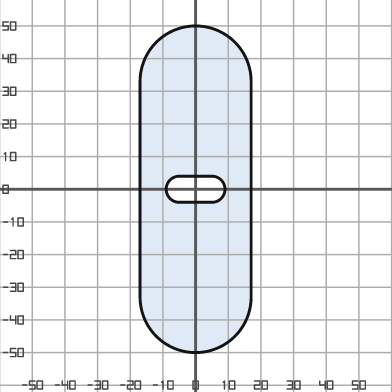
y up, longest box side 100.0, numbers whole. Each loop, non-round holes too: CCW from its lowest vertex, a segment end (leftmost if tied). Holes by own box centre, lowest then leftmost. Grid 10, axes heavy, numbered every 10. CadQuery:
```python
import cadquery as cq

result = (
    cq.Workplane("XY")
    .moveTo(-17.0, -33.0)
    .threePointArc((0.0, -50.0), (17.0, -33.0))
    .lineTo(17.0, 33.0)
    .threePointArc((0.0, 50.0), (-17.0, 33.0))
    .close()
    .moveTo(-5.0, -4.0)
    .lineTo(5.0, -4.0)
    .threePointArc((9.0, 0.0), (5.0, 4.0))
    .lineTo(-5.0, 4.0)
    .threePointArc((-9.0, 0.0), (-5.0, -4.0))
    .close()
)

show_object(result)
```